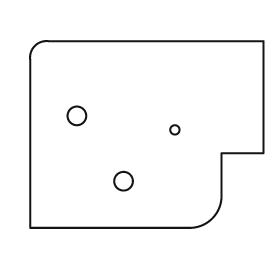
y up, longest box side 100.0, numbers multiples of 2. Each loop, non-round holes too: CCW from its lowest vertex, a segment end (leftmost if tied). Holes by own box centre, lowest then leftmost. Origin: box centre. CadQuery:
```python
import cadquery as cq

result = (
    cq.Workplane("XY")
    .moveTo(-50.0, -40.0)
    .lineTo(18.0, -40.0)
    .threePointArc((28.0, -36.0), (32.0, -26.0))
    .lineTo(32.0, -8.0)
    .lineTo(50.0, -8.0)
    .lineTo(50.0, 40.0)
    .lineTo(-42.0, 40.0)
    .threePointArc((-48.0, 38.0), (-50.0, 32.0))
    .close()
    .moveTo(-10.0, -20.0)
    .circle(4.0)
    .moveTo(12.0, 2.0)
    .circle(2.0)
    .moveTo(-30.0, 8.0)
    .circle(4.0)
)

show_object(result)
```